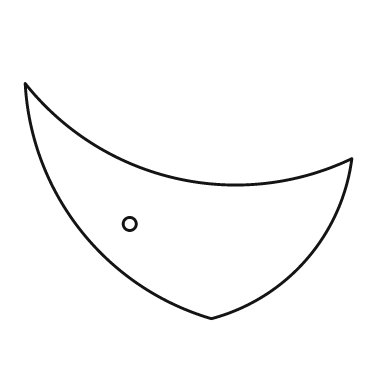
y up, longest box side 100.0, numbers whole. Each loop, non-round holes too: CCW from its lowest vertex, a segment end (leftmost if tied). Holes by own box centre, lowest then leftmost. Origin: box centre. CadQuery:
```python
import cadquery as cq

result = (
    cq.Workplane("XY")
    .moveTo(7.0, -36.0)
    .threePointArc((36.0, -18.0), (50.0, 13.0))
    .threePointArc((-4.0, 7.0), (-50.0, 36.0))
    .threePointArc((-33.0, -9.0), (7.0, -36.0))
    .close()
    .moveTo(-18.0, -7.0)
    .circle(2.0)
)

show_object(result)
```